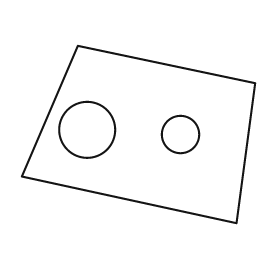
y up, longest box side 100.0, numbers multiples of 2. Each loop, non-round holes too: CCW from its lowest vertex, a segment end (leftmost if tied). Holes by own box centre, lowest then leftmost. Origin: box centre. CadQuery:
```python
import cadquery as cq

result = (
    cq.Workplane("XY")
    .moveTo(42.0, -38.0)
    .lineTo(50.0, 22.0)
    .lineTo(-26.0, 38.0)
    .lineTo(-50.0, -18.0)
    .close()
    .moveTo(18.0, 0.0)
    .circle(8.0)
    .moveTo(-22.0, 2.0)
    .circle(12.0)
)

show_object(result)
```